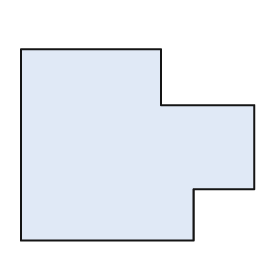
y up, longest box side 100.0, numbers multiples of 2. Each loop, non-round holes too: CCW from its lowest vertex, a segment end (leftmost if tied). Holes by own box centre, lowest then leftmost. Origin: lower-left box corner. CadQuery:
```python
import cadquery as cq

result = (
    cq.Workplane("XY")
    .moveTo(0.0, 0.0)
    .lineTo(74.0, 0.0)
    .lineTo(74.0, 22.0)
    .lineTo(100.0, 22.0)
    .lineTo(100.0, 58.0)
    .lineTo(60.0, 58.0)
    .lineTo(60.0, 82.0)
    .lineTo(0.0, 82.0)
    .close()
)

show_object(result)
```